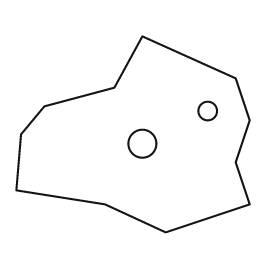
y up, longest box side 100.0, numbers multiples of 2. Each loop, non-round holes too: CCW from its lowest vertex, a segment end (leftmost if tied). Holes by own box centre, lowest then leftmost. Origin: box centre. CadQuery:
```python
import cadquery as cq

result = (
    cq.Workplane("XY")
    .moveTo(14.0, -42.0)
    .lineTo(50.0, -30.0)
    .lineTo(44.0, -12.0)
    .lineTo(50.0, 6.0)
    .lineTo(44.0, 24.0)
    .lineTo(4.0, 42.0)
    .lineTo(-8.0, 20.0)
    .lineTo(-38.0, 12.0)
    .lineTo(-48.0, 0.0)
    .lineTo(-50.0, -24.0)
    .lineTo(-12.0, -30.0)
    .close()
    .moveTo(4.0, -4.0)
    .circle(6.0)
    .moveTo(32.0, 10.0)
    .circle(4.0)
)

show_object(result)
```